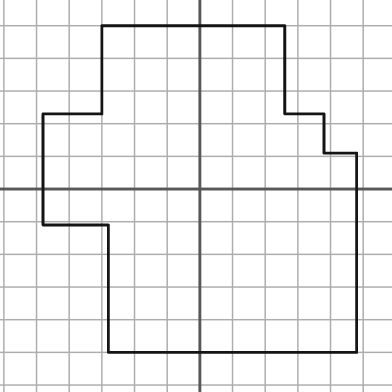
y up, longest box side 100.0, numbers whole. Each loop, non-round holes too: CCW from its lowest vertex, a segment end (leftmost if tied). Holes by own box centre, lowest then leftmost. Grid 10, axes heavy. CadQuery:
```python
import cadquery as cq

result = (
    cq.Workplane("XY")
    .moveTo(-28.0, -50.0)
    .lineTo(48.0, -50.0)
    .lineTo(48.0, 11.0)
    .lineTo(38.0, 11.0)
    .lineTo(38.0, 23.0)
    .lineTo(26.0, 23.0)
    .lineTo(26.0, 50.0)
    .lineTo(-30.0, 50.0)
    .lineTo(-30.0, 23.0)
    .lineTo(-48.0, 23.0)
    .lineTo(-48.0, -11.0)
    .lineTo(-28.0, -11.0)
    .close()
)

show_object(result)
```